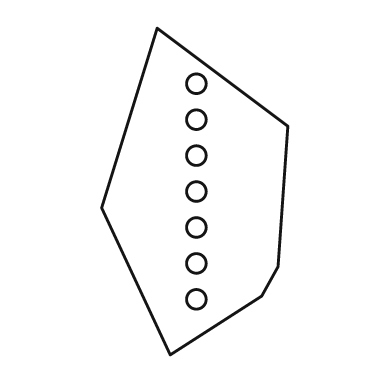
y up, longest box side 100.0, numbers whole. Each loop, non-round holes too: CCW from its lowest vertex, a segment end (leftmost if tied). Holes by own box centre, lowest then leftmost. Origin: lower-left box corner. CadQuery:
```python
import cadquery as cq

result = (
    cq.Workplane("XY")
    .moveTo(21.0, 0.0)
    .lineTo(49.0, 18.0)
    .lineTo(54.0, 27.0)
    .lineTo(57.0, 70.0)
    .lineTo(17.0, 100.0)
    .lineTo(0.0, 45.0)
    .close()
    .moveTo(29.0, 17.0)
    .circle(3.0)
    .moveTo(29.0, 28.0)
    .circle(3.0)
    .moveTo(29.0, 39.0)
    .circle(3.0)
    .moveTo(29.0, 50.0)
    .circle(3.0)
    .moveTo(29.0, 61.0)
    .circle(3.0)
    .moveTo(29.0, 72.0)
    .circle(3.0)
    .moveTo(29.0, 83.0)
    .circle(3.0)
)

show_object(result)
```